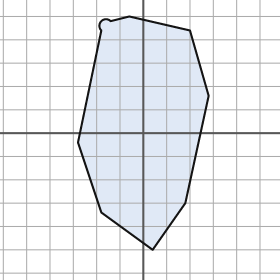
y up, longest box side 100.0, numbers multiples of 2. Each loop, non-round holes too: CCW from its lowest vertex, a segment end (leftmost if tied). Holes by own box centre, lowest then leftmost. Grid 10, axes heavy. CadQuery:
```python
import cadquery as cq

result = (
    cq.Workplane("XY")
    .moveTo(4.0, -50.0)
    .lineTo(18.0, -30.0)
    .lineTo(28.0, 16.0)
    .lineTo(20.0, 44.0)
    .lineTo(-6.0, 50.0)
    .lineTo(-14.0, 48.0)
    .threePointArc((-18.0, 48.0), (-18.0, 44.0))
    .lineTo(-28.0, -4.0)
    .lineTo(-18.0, -34.0)
    .close()
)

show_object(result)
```